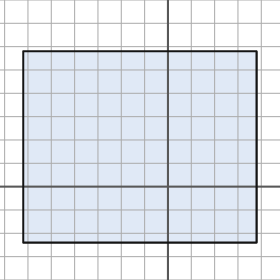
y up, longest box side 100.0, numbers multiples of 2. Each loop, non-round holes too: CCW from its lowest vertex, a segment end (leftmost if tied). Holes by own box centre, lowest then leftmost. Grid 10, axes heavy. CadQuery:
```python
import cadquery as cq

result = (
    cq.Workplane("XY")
    .moveTo(-62.0, -24.0)
    .lineTo(38.0, -24.0)
    .lineTo(38.0, 58.0)
    .lineTo(-62.0, 58.0)
    .close()
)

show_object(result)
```